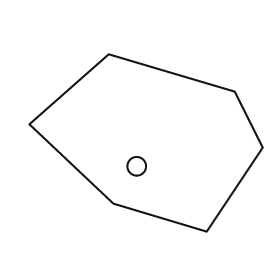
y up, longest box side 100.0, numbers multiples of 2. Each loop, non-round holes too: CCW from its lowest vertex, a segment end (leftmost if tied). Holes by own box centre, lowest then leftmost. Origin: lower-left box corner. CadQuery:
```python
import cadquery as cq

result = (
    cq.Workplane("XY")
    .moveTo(76.0, 0.0)
    .lineTo(100.0, 36.0)
    .lineTo(88.0, 60.0)
    .lineTo(34.0, 76.0)
    .lineTo(0.0, 46.0)
    .lineTo(36.0, 12.0)
    .close()
    .moveTo(46.0, 28.0)
    .circle(4.0)
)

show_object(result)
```